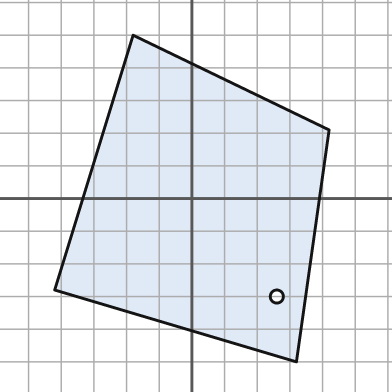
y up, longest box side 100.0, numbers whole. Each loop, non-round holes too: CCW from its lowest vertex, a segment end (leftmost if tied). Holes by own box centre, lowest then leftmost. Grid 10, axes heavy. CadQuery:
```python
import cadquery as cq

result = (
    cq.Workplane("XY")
    .moveTo(32.0, -50.0)
    .lineTo(42.0, 21.0)
    .lineTo(-18.0, 50.0)
    .lineTo(-42.0, -28.0)
    .close()
    .moveTo(26.0, -30.0)
    .circle(2.0)
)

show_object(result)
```